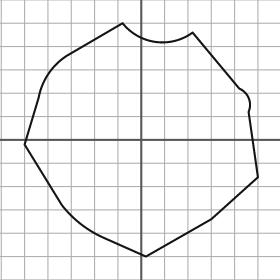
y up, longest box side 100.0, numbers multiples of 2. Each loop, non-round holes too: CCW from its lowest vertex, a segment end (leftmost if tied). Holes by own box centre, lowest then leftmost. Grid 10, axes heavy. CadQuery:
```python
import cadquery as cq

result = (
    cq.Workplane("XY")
    .moveTo(2.0, -50.0)
    .lineTo(30.0, -34.0)
    .lineTo(50.0, -16.0)
    .lineTo(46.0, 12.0)
    .threePointArc((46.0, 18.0), (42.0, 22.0))
    .lineTo(22.0, 46.0)
    .threePointArc((6.0, 42.0), (-8.0, 50.0))
    .lineTo(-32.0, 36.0)
    .threePointArc((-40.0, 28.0), (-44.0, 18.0))
    .lineTo(-50.0, -2.0)
    .lineTo(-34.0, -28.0)
    .threePointArc((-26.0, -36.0), (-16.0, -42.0))
    .close()
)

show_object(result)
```